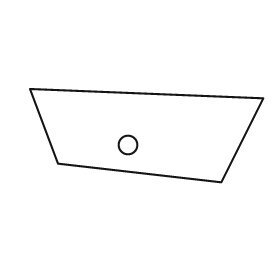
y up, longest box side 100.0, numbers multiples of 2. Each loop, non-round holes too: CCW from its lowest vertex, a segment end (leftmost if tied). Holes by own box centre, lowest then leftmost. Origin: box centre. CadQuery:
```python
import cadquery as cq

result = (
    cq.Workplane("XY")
    .moveTo(32.0, -20.0)
    .lineTo(50.0, 16.0)
    .lineTo(-50.0, 20.0)
    .lineTo(-38.0, -12.0)
    .close()
    .moveTo(-8.0, -4.0)
    .circle(4.0)
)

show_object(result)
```